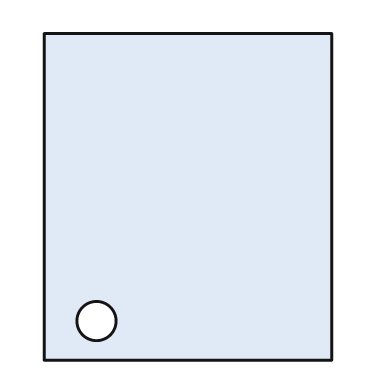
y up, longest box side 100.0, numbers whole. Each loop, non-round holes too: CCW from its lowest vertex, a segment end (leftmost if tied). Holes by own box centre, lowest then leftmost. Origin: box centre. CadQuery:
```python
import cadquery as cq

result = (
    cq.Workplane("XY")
    .moveTo(-44.0, -50.0)
    .lineTo(44.0, -50.0)
    .lineTo(44.0, 50.0)
    .lineTo(-44.0, 50.0)
    .close()
    .moveTo(-28.0, -38.0)
    .circle(6.0)
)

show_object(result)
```